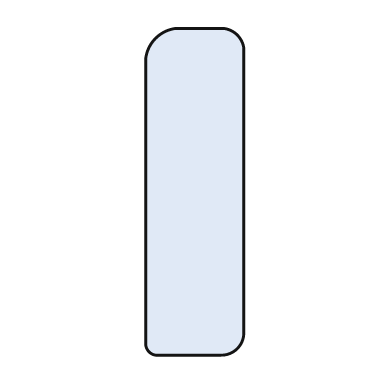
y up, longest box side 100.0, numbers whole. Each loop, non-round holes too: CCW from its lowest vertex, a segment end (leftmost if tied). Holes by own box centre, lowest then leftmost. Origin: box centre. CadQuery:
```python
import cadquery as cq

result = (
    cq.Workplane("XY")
    .moveTo(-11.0, -50.0)
    .lineTo(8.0, -50.0)
    .threePointArc((13.0, -48.0), (15.0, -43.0))
    .lineTo(15.0, 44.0)
    .threePointArc((13.0, 48.0), (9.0, 50.0))
    .lineTo(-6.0, 50.0)
    .threePointArc((-12.0, 47.0), (-15.0, 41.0))
    .lineTo(-15.0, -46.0)
    .threePointArc((-14.0, -49.0), (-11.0, -50.0))
    .close()
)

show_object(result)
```